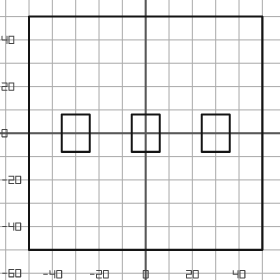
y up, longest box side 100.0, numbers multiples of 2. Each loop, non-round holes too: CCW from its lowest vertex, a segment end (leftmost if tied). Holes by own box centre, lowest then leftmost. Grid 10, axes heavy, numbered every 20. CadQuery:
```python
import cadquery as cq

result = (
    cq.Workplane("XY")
    .moveTo(-50.0, -50.0)
    .lineTo(50.0, -50.0)
    .lineTo(50.0, 50.0)
    .lineTo(-50.0, 50.0)
    .close()
    .moveTo(-36.0, -8.0)
    .lineTo(-24.0, -8.0)
    .lineTo(-24.0, 8.0)
    .lineTo(-36.0, 8.0)
    .close()
    .moveTo(-6.0, -8.0)
    .lineTo(6.0, -8.0)
    .lineTo(6.0, 8.0)
    .lineTo(-6.0, 8.0)
    .close()
    .moveTo(24.0, -8.0)
    .lineTo(36.0, -8.0)
    .lineTo(36.0, 8.0)
    .lineTo(24.0, 8.0)
    .close()
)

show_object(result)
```